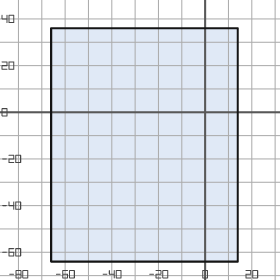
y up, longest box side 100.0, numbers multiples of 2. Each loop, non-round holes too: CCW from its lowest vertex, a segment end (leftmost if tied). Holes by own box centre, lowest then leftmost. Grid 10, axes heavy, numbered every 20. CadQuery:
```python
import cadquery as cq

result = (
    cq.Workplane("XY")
    .moveTo(-66.0, -64.0)
    .lineTo(14.0, -64.0)
    .lineTo(14.0, 36.0)
    .lineTo(-66.0, 36.0)
    .close()
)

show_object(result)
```